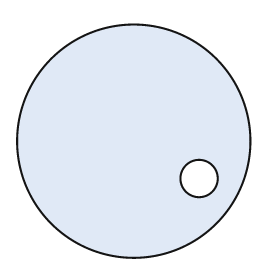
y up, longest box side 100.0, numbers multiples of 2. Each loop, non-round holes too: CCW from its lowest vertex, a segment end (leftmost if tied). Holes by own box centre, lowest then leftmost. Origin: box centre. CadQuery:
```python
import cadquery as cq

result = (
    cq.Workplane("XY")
    .moveTo(0.0, 0.0)
    .circle(50.0)
    .moveTo(28.0, -16.0)
    .circle(8.0)
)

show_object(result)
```